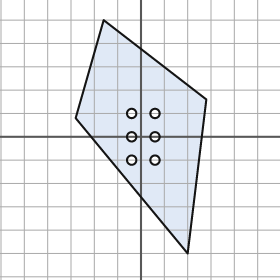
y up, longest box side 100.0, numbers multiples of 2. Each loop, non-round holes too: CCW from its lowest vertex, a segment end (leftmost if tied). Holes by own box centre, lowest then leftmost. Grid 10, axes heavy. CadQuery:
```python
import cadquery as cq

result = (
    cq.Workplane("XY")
    .moveTo(20.0, -50.0)
    .lineTo(28.0, 16.0)
    .lineTo(-16.0, 50.0)
    .lineTo(-28.0, 8.0)
    .close()
    .moveTo(-4.0, -10.0)
    .circle(2.0)
    .moveTo(6.0, -10.0)
    .circle(2.0)
    .moveTo(-4.0, 0.0)
    .circle(2.0)
    .moveTo(6.0, 0.0)
    .circle(2.0)
    .moveTo(-4.0, 10.0)
    .circle(2.0)
    .moveTo(6.0, 10.0)
    .circle(2.0)
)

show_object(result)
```